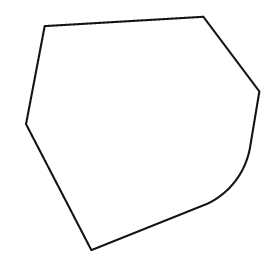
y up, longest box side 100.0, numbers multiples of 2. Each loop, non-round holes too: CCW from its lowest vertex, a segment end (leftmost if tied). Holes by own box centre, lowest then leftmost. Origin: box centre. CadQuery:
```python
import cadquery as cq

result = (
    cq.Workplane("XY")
    .moveTo(-22.0, -50.0)
    .lineTo(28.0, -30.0)
    .threePointArc((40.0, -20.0), (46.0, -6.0))
    .lineTo(50.0, 18.0)
    .lineTo(26.0, 50.0)
    .lineTo(-42.0, 46.0)
    .lineTo(-50.0, 4.0)
    .close()
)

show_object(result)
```